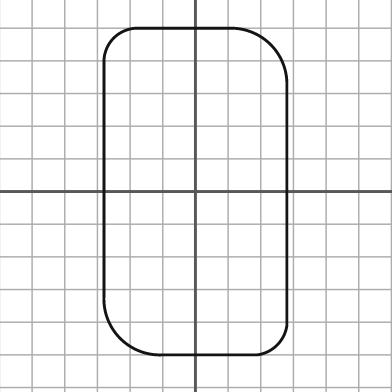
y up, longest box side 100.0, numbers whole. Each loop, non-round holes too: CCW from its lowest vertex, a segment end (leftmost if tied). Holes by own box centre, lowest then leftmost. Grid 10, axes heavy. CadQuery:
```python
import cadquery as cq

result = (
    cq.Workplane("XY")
    .moveTo(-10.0, -50.0)
    .lineTo(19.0, -50.0)
    .threePointArc((25.0, -47.0), (28.0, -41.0))
    .lineTo(28.0, 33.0)
    .threePointArc((23.0, 45.0), (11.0, 50.0))
    .lineTo(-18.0, 50.0)
    .threePointArc((-25.0, 47.0), (-28.0, 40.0))
    .lineTo(-28.0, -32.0)
    .threePointArc((-23.0, -45.0), (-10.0, -50.0))
    .close()
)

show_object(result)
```